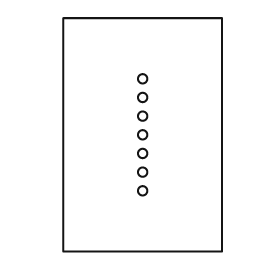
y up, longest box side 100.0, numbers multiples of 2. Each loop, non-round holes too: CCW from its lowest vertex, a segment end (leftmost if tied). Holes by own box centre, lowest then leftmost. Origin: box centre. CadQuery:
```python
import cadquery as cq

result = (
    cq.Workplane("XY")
    .moveTo(-34.0, -50.0)
    .lineTo(34.0, -50.0)
    .lineTo(34.0, 50.0)
    .lineTo(-34.0, 50.0)
    .close()
    .moveTo(0.0, -24.0)
    .circle(2.0)
    .moveTo(0.0, -16.0)
    .circle(2.0)
    .moveTo(0.0, -8.0)
    .circle(2.0)
    .moveTo(0.0, 0.0)
    .circle(2.0)
    .moveTo(0.0, 8.0)
    .circle(2.0)
    .moveTo(0.0, 16.0)
    .circle(2.0)
    .moveTo(0.0, 24.0)
    .circle(2.0)
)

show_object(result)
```